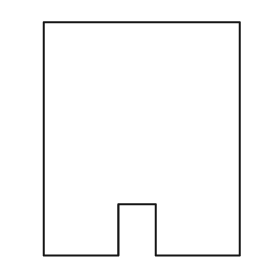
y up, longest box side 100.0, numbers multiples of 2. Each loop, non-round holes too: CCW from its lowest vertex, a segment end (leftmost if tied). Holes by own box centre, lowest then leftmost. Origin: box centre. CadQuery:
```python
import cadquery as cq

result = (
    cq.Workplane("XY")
    .moveTo(-42.0, -50.0)
    .lineTo(-10.0, -50.0)
    .lineTo(-10.0, -28.0)
    .lineTo(6.0, -28.0)
    .lineTo(6.0, -50.0)
    .lineTo(42.0, -50.0)
    .lineTo(42.0, 50.0)
    .lineTo(-42.0, 50.0)
    .close()
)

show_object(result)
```